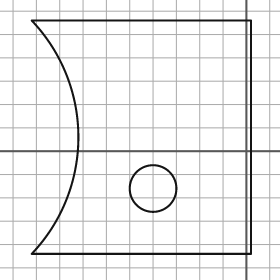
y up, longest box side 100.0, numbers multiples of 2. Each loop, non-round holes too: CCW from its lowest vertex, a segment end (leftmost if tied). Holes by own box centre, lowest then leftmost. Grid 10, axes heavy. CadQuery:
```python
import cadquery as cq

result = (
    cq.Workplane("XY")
    .moveTo(-92.0, -44.0)
    .lineTo(2.0, -44.0)
    .lineTo(2.0, 56.0)
    .lineTo(-92.0, 56.0)
    .threePointArc((-72.0, 6.0), (-92.0, -44.0))
    .close()
    .moveTo(-40.0, -16.0)
    .circle(10.0)
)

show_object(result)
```